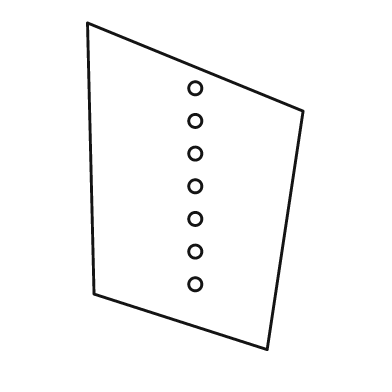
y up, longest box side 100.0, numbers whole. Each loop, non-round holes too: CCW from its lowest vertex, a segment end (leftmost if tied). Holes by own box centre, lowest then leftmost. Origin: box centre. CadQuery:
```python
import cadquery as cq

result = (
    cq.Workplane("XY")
    .moveTo(22.0, -50.0)
    .lineTo(33.0, 23.0)
    .lineTo(-33.0, 50.0)
    .lineTo(-31.0, -33.0)
    .close()
    .moveTo(0.0, -30.0)
    .circle(2.0)
    .moveTo(0.0, -20.0)
    .circle(2.0)
    .moveTo(0.0, -10.0)
    .circle(2.0)
    .moveTo(0.0, 0.0)
    .circle(2.0)
    .moveTo(0.0, 10.0)
    .circle(2.0)
    .moveTo(0.0, 20.0)
    .circle(2.0)
    .moveTo(0.0, 30.0)
    .circle(2.0)
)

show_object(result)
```